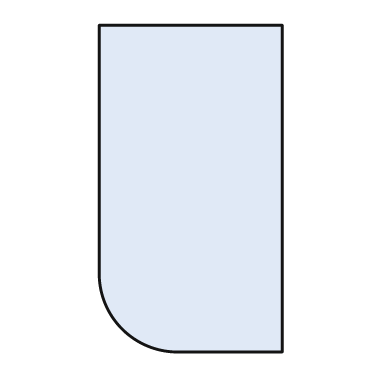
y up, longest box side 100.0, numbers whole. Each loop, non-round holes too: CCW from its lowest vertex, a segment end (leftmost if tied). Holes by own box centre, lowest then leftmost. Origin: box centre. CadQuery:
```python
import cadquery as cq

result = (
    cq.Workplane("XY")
    .moveTo(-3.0, -50.0)
    .lineTo(28.0, -50.0)
    .lineTo(28.0, 50.0)
    .lineTo(-28.0, 50.0)
    .lineTo(-28.0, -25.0)
    .threePointArc((-21.0, -43.0), (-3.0, -50.0))
    .close()
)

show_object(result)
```